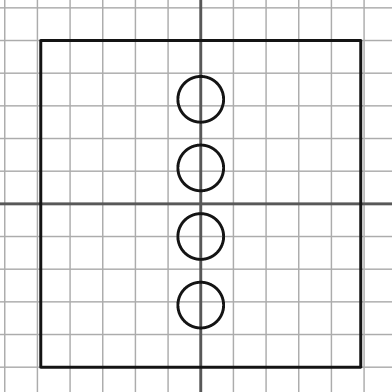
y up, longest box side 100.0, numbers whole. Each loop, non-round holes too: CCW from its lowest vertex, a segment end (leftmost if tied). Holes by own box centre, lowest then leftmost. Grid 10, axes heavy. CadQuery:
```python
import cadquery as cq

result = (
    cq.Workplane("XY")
    .moveTo(-49.0, -50.0)
    .lineTo(49.0, -50.0)
    .lineTo(49.0, 50.0)
    .lineTo(-49.0, 50.0)
    .close()
    .moveTo(0.0, -31.0)
    .circle(7.0)
    .moveTo(0.0, -10.0)
    .circle(7.0)
    .moveTo(0.0, 11.0)
    .circle(7.0)
    .moveTo(0.0, 32.0)
    .circle(7.0)
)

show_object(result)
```